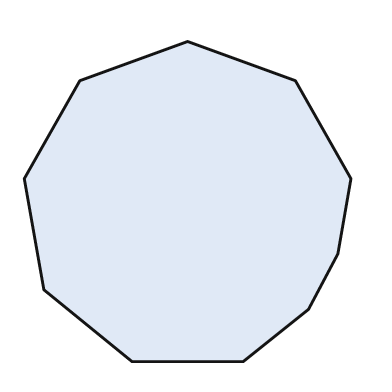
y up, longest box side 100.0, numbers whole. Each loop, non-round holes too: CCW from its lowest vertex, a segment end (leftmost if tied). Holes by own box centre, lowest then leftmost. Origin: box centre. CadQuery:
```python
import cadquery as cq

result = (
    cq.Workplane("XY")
    .moveTo(-17.0, -49.0)
    .lineTo(17.0, -49.0)
    .lineTo(37.0, -33.0)
    .lineTo(46.0, -16.0)
    .lineTo(50.0, 7.0)
    .lineTo(33.0, 37.0)
    .lineTo(0.0, 49.0)
    .lineTo(-33.0, 37.0)
    .lineTo(-50.0, 7.0)
    .lineTo(-44.0, -27.0)
    .close()
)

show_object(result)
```